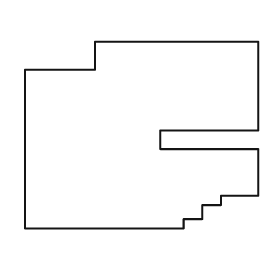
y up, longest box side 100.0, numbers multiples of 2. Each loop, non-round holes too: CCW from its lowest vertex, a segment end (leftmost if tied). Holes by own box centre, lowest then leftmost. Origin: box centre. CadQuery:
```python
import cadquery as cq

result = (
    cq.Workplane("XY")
    .moveTo(-50.0, -40.0)
    .lineTo(18.0, -40.0)
    .lineTo(18.0, -36.0)
    .lineTo(26.0, -36.0)
    .lineTo(26.0, -30.0)
    .lineTo(34.0, -30.0)
    .lineTo(34.0, -26.0)
    .lineTo(50.0, -26.0)
    .lineTo(50.0, -6.0)
    .lineTo(8.0, -6.0)
    .lineTo(8.0, 2.0)
    .lineTo(50.0, 2.0)
    .lineTo(50.0, 40.0)
    .lineTo(-20.0, 40.0)
    .lineTo(-20.0, 28.0)
    .lineTo(-50.0, 28.0)
    .close()
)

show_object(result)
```